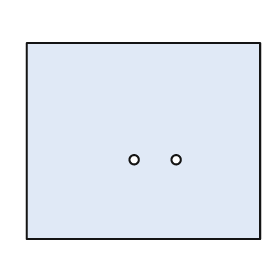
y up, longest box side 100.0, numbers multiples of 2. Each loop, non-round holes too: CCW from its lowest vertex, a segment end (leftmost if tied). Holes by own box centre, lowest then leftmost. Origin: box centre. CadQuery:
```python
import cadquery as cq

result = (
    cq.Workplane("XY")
    .moveTo(-50.0, -42.0)
    .lineTo(50.0, -42.0)
    .lineTo(50.0, 42.0)
    .lineTo(-50.0, 42.0)
    .close()
    .moveTo(-4.0, -8.0)
    .circle(2.0)
    .moveTo(14.0, -8.0)
    .circle(2.0)
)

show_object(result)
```